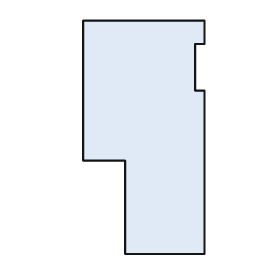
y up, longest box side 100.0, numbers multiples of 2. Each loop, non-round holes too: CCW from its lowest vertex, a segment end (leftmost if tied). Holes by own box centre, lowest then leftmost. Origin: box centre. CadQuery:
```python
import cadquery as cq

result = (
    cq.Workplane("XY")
    .moveTo(-8.0, -50.0)
    .lineTo(26.0, -50.0)
    .lineTo(26.0, 20.0)
    .lineTo(22.0, 20.0)
    .lineTo(22.0, 40.0)
    .lineTo(26.0, 40.0)
    .lineTo(26.0, 50.0)
    .lineTo(-26.0, 50.0)
    .lineTo(-26.0, -10.0)
    .lineTo(-8.0, -10.0)
    .close()
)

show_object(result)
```